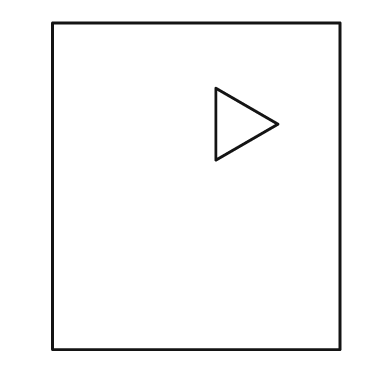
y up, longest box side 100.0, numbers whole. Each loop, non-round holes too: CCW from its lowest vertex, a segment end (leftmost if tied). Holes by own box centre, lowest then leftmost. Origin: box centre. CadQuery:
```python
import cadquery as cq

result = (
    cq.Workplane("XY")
    .moveTo(-44.0, -50.0)
    .lineTo(44.0, -50.0)
    .lineTo(44.0, 50.0)
    .lineTo(-44.0, 50.0)
    .close()
    .moveTo(6.0, 8.0)
    .lineTo(25.0, 19.0)
    .lineTo(6.0, 30.0)
    .close()
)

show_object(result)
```